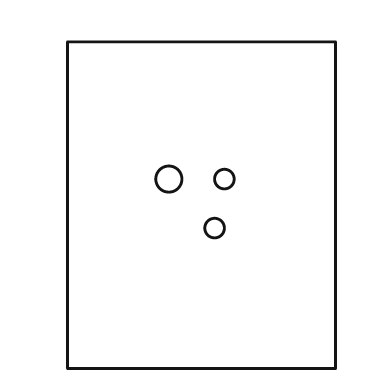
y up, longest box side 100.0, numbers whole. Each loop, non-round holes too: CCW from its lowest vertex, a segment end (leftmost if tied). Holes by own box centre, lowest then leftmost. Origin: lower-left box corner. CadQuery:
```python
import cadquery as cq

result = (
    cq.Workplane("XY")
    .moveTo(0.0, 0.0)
    .lineTo(82.0, 0.0)
    .lineTo(82.0, 100.0)
    .lineTo(0.0, 100.0)
    .close()
    .moveTo(45.0, 43.0)
    .circle(3.0)
    .moveTo(31.0, 58.0)
    .circle(4.0)
    .moveTo(48.0, 58.0)
    .circle(3.0)
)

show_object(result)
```